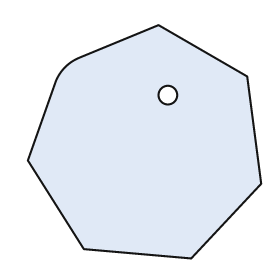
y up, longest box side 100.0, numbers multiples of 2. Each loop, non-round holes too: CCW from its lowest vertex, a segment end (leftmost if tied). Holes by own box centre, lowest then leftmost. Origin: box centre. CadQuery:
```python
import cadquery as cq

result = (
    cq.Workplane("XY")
    .moveTo(20.0, -50.0)
    .lineTo(50.0, -18.0)
    .lineTo(44.0, 28.0)
    .lineTo(6.0, 50.0)
    .lineTo(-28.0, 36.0)
    .threePointArc((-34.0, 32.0), (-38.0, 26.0))
    .lineTo(-50.0, -8.0)
    .lineTo(-26.0, -46.0)
    .close()
    .moveTo(10.0, 20.0)
    .circle(4.0)
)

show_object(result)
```